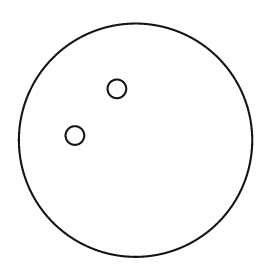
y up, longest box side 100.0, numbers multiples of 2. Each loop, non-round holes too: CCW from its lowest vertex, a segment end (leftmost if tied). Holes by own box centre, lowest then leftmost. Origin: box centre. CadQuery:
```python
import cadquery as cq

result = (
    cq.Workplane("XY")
    .moveTo(0.0, 0.0)
    .circle(50.0)
    .moveTo(-26.0, 2.0)
    .circle(4.0)
    .moveTo(-8.0, 22.0)
    .circle(4.0)
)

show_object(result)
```